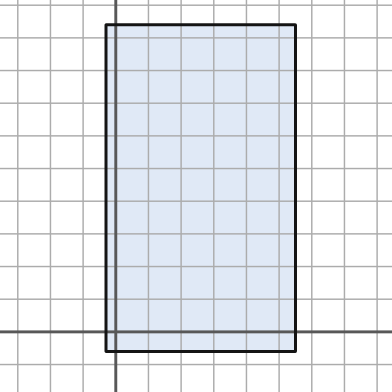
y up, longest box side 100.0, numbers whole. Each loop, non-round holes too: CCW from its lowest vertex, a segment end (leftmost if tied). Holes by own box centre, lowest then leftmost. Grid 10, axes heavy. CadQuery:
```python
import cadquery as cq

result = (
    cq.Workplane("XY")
    .moveTo(-3.0, -6.0)
    .lineTo(55.0, -6.0)
    .lineTo(55.0, 94.0)
    .lineTo(-3.0, 94.0)
    .close()
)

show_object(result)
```